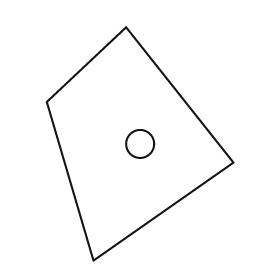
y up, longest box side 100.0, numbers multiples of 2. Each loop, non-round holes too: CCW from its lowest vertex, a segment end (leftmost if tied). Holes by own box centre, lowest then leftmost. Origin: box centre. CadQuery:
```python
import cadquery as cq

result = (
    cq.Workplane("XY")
    .moveTo(-20.0, -50.0)
    .lineTo(40.0, -8.0)
    .lineTo(-6.0, 50.0)
    .lineTo(-40.0, 18.0)
    .close()
    .moveTo(0.0, 0.0)
    .circle(6.0)
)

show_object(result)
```